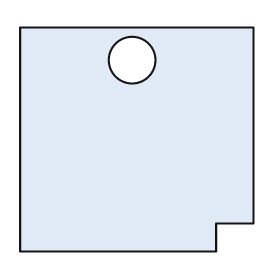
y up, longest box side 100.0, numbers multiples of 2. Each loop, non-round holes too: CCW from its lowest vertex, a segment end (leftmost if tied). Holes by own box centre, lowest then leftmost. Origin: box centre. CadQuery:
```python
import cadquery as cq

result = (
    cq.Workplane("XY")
    .moveTo(-50.0, -48.0)
    .lineTo(34.0, -48.0)
    .lineTo(34.0, -36.0)
    .lineTo(50.0, -36.0)
    .lineTo(50.0, 48.0)
    .lineTo(-50.0, 48.0)
    .close()
    .moveTo(-2.0, 34.0)
    .circle(10.0)
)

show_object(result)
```